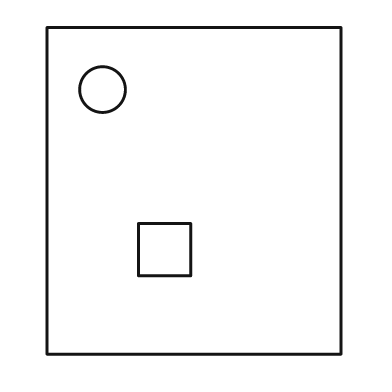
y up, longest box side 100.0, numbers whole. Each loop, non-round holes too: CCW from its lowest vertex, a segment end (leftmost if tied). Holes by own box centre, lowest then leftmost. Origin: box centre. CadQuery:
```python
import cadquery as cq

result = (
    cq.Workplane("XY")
    .moveTo(-45.0, -50.0)
    .lineTo(45.0, -50.0)
    .lineTo(45.0, 50.0)
    .lineTo(-45.0, 50.0)
    .close()
    .moveTo(-17.0, -26.0)
    .lineTo(-1.0, -26.0)
    .lineTo(-1.0, -10.0)
    .lineTo(-17.0, -10.0)
    .close()
    .moveTo(-28.0, 31.0)
    .circle(7.0)
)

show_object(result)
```